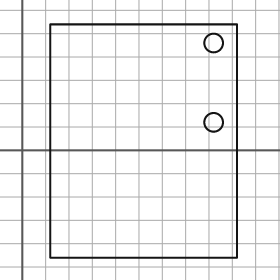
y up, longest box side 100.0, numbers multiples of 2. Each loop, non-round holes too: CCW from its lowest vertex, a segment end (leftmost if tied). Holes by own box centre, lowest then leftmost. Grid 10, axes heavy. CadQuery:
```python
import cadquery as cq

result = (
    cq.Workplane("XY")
    .moveTo(12.0, -46.0)
    .lineTo(92.0, -46.0)
    .lineTo(92.0, 54.0)
    .lineTo(12.0, 54.0)
    .close()
    .moveTo(82.0, 12.0)
    .circle(4.0)
    .moveTo(82.0, 46.0)
    .circle(4.0)
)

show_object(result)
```